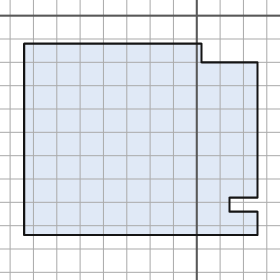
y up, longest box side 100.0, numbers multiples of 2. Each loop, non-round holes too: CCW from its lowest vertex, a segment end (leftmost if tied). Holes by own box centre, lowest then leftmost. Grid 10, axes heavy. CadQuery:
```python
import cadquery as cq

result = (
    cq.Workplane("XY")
    .moveTo(-74.0, -94.0)
    .lineTo(26.0, -94.0)
    .lineTo(26.0, -84.0)
    .lineTo(14.0, -84.0)
    .lineTo(14.0, -78.0)
    .lineTo(26.0, -78.0)
    .lineTo(26.0, -20.0)
    .lineTo(2.0, -20.0)
    .lineTo(2.0, -12.0)
    .lineTo(-74.0, -12.0)
    .close()
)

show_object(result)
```